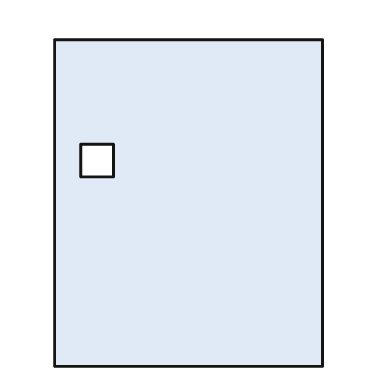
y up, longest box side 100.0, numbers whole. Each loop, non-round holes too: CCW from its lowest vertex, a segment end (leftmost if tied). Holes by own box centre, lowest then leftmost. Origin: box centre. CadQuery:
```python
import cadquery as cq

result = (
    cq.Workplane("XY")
    .moveTo(-41.0, -50.0)
    .lineTo(41.0, -50.0)
    .lineTo(41.0, 50.0)
    .lineTo(-41.0, 50.0)
    .close()
    .moveTo(-33.0, 8.0)
    .lineTo(-23.0, 8.0)
    .lineTo(-23.0, 18.0)
    .lineTo(-33.0, 18.0)
    .close()
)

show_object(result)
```